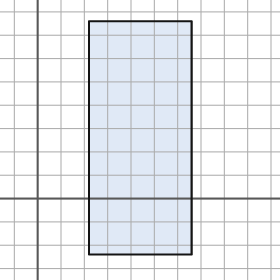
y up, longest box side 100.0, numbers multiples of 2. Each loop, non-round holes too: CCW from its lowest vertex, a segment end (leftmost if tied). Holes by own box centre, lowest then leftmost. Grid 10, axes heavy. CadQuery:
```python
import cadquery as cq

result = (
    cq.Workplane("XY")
    .moveTo(22.0, -24.0)
    .lineTo(66.0, -24.0)
    .lineTo(66.0, 76.0)
    .lineTo(22.0, 76.0)
    .close()
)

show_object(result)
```